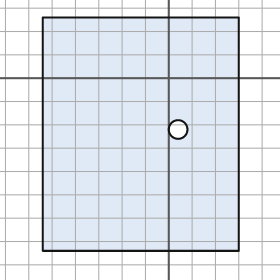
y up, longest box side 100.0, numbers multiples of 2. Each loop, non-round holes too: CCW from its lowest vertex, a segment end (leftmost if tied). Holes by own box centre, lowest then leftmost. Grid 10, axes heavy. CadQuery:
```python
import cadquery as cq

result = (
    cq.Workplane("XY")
    .moveTo(-54.0, -74.0)
    .lineTo(30.0, -74.0)
    .lineTo(30.0, 26.0)
    .lineTo(-54.0, 26.0)
    .close()
    .moveTo(4.0, -22.0)
    .circle(4.0)
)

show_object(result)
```